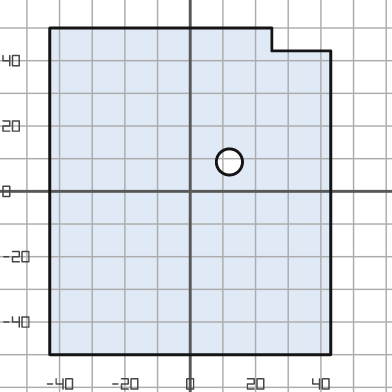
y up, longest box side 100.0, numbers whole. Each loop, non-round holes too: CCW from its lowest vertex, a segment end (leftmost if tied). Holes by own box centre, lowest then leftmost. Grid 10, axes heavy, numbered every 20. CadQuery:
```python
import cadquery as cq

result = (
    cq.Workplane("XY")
    .moveTo(-43.0, -50.0)
    .lineTo(43.0, -50.0)
    .lineTo(43.0, 43.0)
    .lineTo(25.0, 43.0)
    .lineTo(25.0, 50.0)
    .lineTo(-43.0, 50.0)
    .close()
    .moveTo(12.0, 9.0)
    .circle(4.0)
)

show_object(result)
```